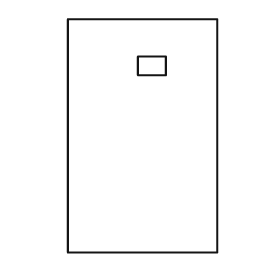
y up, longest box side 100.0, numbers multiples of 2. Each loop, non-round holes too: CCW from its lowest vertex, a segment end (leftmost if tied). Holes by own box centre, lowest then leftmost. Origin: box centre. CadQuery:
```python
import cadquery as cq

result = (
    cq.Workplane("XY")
    .moveTo(-32.0, -50.0)
    .lineTo(32.0, -50.0)
    .lineTo(32.0, 50.0)
    .lineTo(-32.0, 50.0)
    .close()
    .moveTo(-2.0, 26.0)
    .lineTo(10.0, 26.0)
    .lineTo(10.0, 34.0)
    .lineTo(-2.0, 34.0)
    .close()
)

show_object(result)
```